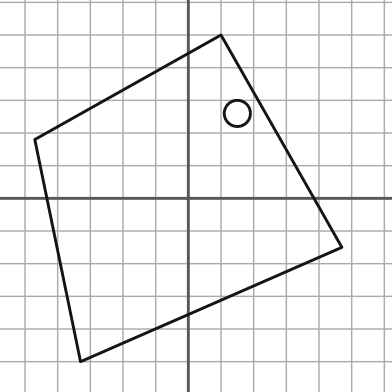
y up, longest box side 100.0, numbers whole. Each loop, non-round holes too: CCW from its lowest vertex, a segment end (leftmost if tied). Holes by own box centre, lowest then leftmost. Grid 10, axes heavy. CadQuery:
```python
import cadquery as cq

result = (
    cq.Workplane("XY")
    .moveTo(-33.0, -50.0)
    .lineTo(47.0, -15.0)
    .lineTo(10.0, 50.0)
    .lineTo(-47.0, 18.0)
    .close()
    .moveTo(15.0, 26.0)
    .circle(4.0)
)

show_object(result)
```